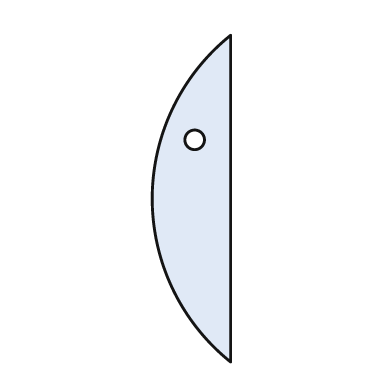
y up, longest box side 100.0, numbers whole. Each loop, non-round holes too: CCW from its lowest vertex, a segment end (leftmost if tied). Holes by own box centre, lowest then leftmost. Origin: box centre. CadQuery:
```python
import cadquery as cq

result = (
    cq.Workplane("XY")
    .moveTo(12.0, -50.0)
    .lineTo(12.0, 50.0)
    .threePointArc((-12.0, 0.0), (12.0, -50.0))
    .close()
    .moveTo(1.0, 18.0)
    .circle(3.0)
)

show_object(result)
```